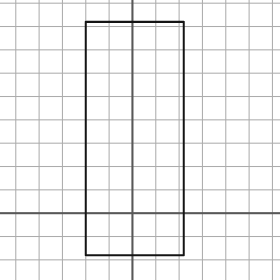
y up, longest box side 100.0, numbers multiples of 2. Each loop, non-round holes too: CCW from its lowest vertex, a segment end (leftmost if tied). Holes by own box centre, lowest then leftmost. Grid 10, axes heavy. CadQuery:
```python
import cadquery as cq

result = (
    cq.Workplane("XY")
    .moveTo(-20.0, -18.0)
    .lineTo(22.0, -18.0)
    .lineTo(22.0, 82.0)
    .lineTo(-20.0, 82.0)
    .close()
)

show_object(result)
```